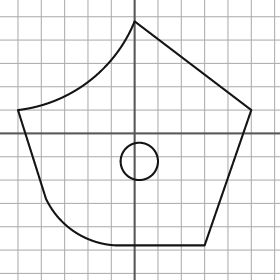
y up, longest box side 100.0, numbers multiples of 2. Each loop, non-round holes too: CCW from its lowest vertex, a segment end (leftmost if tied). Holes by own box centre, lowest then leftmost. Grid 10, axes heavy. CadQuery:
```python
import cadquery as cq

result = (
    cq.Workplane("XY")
    .moveTo(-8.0, -48.0)
    .lineTo(30.0, -48.0)
    .lineTo(50.0, 10.0)
    .lineTo(0.0, 48.0)
    .threePointArc((-20.0, 22.0), (-50.0, 10.0))
    .lineTo(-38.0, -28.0)
    .threePointArc((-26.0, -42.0), (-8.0, -48.0))
    .close()
    .moveTo(2.0, -12.0)
    .circle(8.0)
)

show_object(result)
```